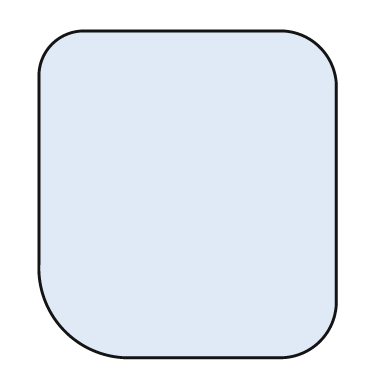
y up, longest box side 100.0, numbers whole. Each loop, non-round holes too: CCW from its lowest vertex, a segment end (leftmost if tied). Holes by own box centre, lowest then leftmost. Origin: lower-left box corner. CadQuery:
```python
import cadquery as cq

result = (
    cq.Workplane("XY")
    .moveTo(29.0, 0.0)
    .lineTo(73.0, 0.0)
    .threePointArc((86.0, 5.0), (91.0, 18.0))
    .lineTo(91.0, 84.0)
    .threePointArc((86.0, 95.0), (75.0, 100.0))
    .lineTo(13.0, 100.0)
    .threePointArc((4.0, 96.0), (0.0, 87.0))
    .lineTo(0.0, 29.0)
    .threePointArc((8.0, 8.0), (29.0, 0.0))
    .close()
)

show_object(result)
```